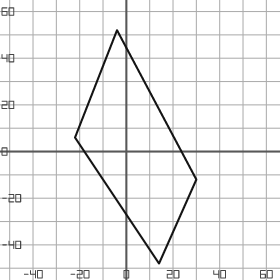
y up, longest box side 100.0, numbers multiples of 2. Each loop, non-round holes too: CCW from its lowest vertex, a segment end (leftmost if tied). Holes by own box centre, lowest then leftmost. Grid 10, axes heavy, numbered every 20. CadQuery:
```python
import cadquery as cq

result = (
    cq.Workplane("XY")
    .moveTo(14.0, -48.0)
    .lineTo(30.0, -12.0)
    .lineTo(-4.0, 52.0)
    .lineTo(-22.0, 6.0)
    .close()
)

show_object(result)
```